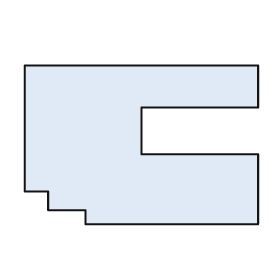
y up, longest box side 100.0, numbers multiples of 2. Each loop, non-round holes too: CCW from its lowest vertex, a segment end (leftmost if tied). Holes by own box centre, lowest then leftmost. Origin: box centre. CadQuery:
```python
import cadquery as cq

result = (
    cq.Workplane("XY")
    .moveTo(-24.0, -34.0)
    .lineTo(50.0, -34.0)
    .lineTo(50.0, -4.0)
    .lineTo(0.0, -4.0)
    .lineTo(0.0, 16.0)
    .lineTo(50.0, 16.0)
    .lineTo(50.0, 34.0)
    .lineTo(-50.0, 34.0)
    .lineTo(-50.0, -20.0)
    .lineTo(-40.0, -20.0)
    .lineTo(-40.0, -28.0)
    .lineTo(-24.0, -28.0)
    .close()
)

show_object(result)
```